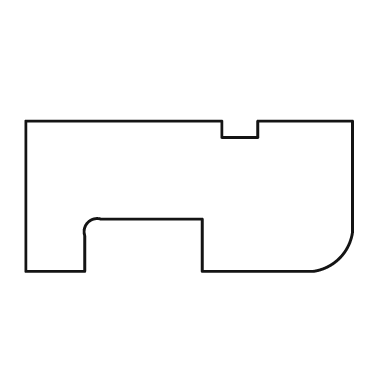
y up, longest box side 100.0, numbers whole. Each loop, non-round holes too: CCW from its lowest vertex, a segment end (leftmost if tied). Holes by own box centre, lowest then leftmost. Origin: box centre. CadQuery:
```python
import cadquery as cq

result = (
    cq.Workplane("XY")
    .moveTo(-50.0, -23.0)
    .lineTo(-32.0, -23.0)
    .lineTo(-32.0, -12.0)
    .threePointArc((-31.0, -8.0), (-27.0, -7.0))
    .lineTo(4.0, -7.0)
    .lineTo(4.0, -23.0)
    .lineTo(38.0, -23.0)
    .threePointArc((46.0, -19.0), (50.0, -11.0))
    .lineTo(50.0, 23.0)
    .lineTo(21.0, 23.0)
    .lineTo(21.0, 18.0)
    .lineTo(10.0, 18.0)
    .lineTo(10.0, 23.0)
    .lineTo(-50.0, 23.0)
    .close()
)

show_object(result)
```